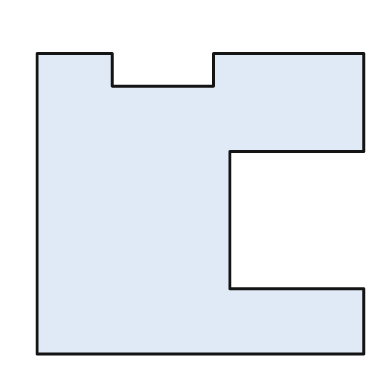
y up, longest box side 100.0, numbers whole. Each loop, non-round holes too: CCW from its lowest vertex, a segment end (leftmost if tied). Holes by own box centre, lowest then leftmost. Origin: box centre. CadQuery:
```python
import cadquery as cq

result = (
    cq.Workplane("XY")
    .moveTo(-50.0, -46.0)
    .lineTo(50.0, -46.0)
    .lineTo(50.0, -26.0)
    .lineTo(9.0, -26.0)
    .lineTo(9.0, 16.0)
    .lineTo(50.0, 16.0)
    .lineTo(50.0, 46.0)
    .lineTo(4.0, 46.0)
    .lineTo(4.0, 36.0)
    .lineTo(-27.0, 36.0)
    .lineTo(-27.0, 46.0)
    .lineTo(-50.0, 46.0)
    .close()
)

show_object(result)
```